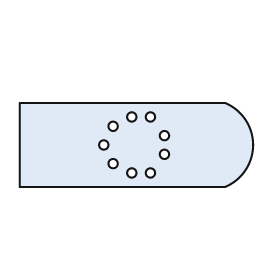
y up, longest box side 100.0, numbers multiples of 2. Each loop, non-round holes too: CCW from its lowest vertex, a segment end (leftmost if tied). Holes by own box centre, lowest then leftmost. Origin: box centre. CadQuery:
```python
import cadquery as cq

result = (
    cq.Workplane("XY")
    .moveTo(-50.0, -18.0)
    .lineTo(38.0, -18.0)
    .threePointArc((50.0, 0.0), (38.0, 18.0))
    .lineTo(-50.0, 18.0)
    .close()
    .moveTo(-2.0, -12.0)
    .circle(2.0)
    .moveTo(6.0, -12.0)
    .circle(2.0)
    .moveTo(-10.0, -8.0)
    .circle(2.0)
    .moveTo(12.0, -4.0)
    .circle(2.0)
    .moveTo(-14.0, 0.0)
    .circle(2.0)
    .moveTo(12.0, 4.0)
    .circle(2.0)
    .moveTo(-10.0, 8.0)
    .circle(2.0)
    .moveTo(-2.0, 12.0)
    .circle(2.0)
    .moveTo(6.0, 12.0)
    .circle(2.0)
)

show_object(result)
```